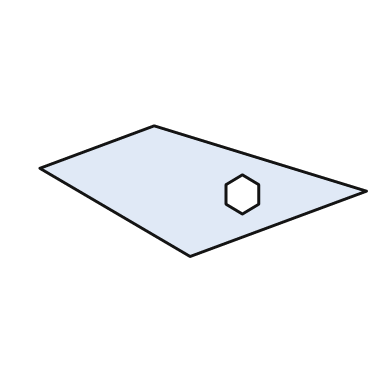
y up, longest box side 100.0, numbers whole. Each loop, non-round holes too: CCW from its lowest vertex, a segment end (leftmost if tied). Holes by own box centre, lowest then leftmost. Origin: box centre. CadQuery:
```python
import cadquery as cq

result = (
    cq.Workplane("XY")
    .moveTo(-4.0, -20.0)
    .lineTo(50.0, 0.0)
    .lineTo(-15.0, 20.0)
    .lineTo(-50.0, 7.0)
    .close()
    .moveTo(12.0, -7.0)
    .lineTo(17.0, -4.0)
    .lineTo(17.0, 2.0)
    .lineTo(12.0, 5.0)
    .lineTo(7.0, 2.0)
    .lineTo(7.0, -4.0)
    .close()
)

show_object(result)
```